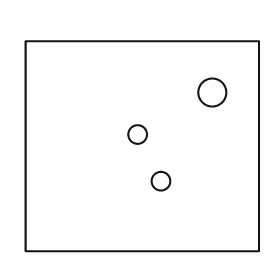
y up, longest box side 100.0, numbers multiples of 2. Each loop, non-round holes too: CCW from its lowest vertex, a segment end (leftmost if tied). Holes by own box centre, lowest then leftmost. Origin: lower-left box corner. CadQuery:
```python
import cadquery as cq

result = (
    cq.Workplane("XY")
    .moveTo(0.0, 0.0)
    .lineTo(100.0, 0.0)
    .lineTo(100.0, 90.0)
    .lineTo(0.0, 90.0)
    .close()
    .moveTo(58.0, 30.0)
    .circle(4.0)
    .moveTo(48.0, 50.0)
    .circle(4.0)
    .moveTo(80.0, 68.0)
    .circle(6.0)
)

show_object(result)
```